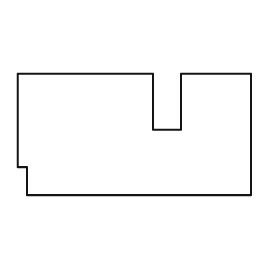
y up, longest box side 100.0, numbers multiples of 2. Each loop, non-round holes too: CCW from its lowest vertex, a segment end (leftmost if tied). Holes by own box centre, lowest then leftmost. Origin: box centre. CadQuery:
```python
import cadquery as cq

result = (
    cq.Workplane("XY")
    .moveTo(-46.0, -26.0)
    .lineTo(50.0, -26.0)
    .lineTo(50.0, 26.0)
    .lineTo(20.0, 26.0)
    .lineTo(20.0, 2.0)
    .lineTo(8.0, 2.0)
    .lineTo(8.0, 26.0)
    .lineTo(-50.0, 26.0)
    .lineTo(-50.0, -14.0)
    .lineTo(-46.0, -14.0)
    .close()
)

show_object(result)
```